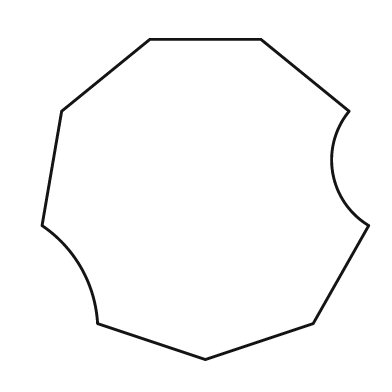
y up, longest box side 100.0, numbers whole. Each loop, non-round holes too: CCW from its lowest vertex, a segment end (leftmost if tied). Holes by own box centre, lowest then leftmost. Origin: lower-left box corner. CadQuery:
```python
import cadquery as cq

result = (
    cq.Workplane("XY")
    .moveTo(50.0, 0.0)
    .lineTo(83.0, 11.0)
    .lineTo(100.0, 41.0)
    .threePointArc((89.0, 57.0), (94.0, 76.0))
    .lineTo(67.0, 98.0)
    .lineTo(33.0, 98.0)
    .lineTo(6.0, 76.0)
    .lineTo(0.0, 41.0)
    .threePointArc((12.0, 28.0), (17.0, 11.0))
    .close()
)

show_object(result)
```